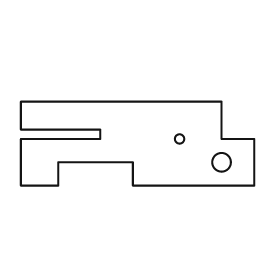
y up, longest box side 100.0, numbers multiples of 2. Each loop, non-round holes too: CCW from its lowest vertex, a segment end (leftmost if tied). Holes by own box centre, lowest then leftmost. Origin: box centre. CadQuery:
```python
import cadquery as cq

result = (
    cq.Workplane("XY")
    .moveTo(-50.0, -18.0)
    .lineTo(-34.0, -18.0)
    .lineTo(-34.0, -8.0)
    .lineTo(-2.0, -8.0)
    .lineTo(-2.0, -18.0)
    .lineTo(50.0, -18.0)
    .lineTo(50.0, 2.0)
    .lineTo(36.0, 2.0)
    .lineTo(36.0, 18.0)
    .lineTo(-50.0, 18.0)
    .lineTo(-50.0, 6.0)
    .lineTo(-16.0, 6.0)
    .lineTo(-16.0, 2.0)
    .lineTo(-50.0, 2.0)
    .close()
    .moveTo(36.0, -8.0)
    .circle(4.0)
    .moveTo(18.0, 2.0)
    .circle(2.0)
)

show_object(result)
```